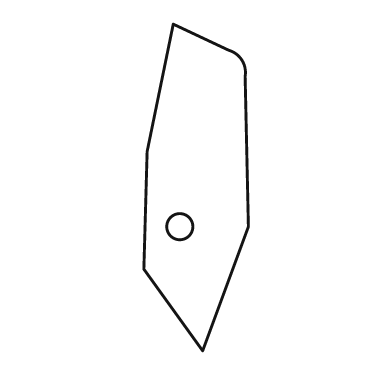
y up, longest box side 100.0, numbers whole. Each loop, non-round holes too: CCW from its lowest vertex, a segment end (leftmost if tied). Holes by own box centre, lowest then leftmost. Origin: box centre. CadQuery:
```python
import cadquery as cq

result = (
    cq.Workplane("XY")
    .moveTo(2.0, -50.0)
    .lineTo(16.0, -12.0)
    .lineTo(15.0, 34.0)
    .threePointArc((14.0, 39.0), (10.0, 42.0))
    .lineTo(-7.0, 50.0)
    .lineTo(-15.0, 11.0)
    .lineTo(-16.0, -25.0)
    .close()
    .moveTo(-5.0, -12.0)
    .circle(4.0)
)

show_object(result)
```